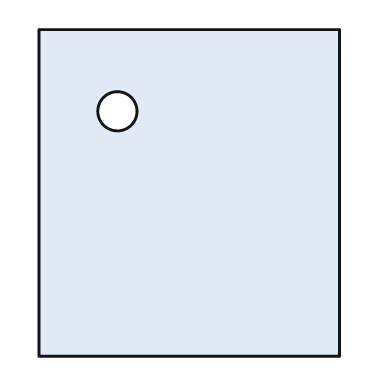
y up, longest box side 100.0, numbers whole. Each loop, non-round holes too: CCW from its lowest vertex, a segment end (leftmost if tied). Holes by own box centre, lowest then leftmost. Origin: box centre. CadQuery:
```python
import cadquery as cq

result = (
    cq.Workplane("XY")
    .moveTo(-46.0, -50.0)
    .lineTo(46.0, -50.0)
    .lineTo(46.0, 50.0)
    .lineTo(-46.0, 50.0)
    .close()
    .moveTo(-22.0, 25.0)
    .circle(6.0)
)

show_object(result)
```